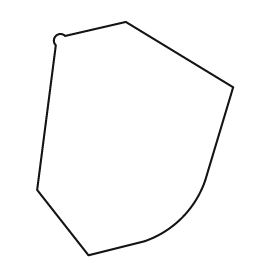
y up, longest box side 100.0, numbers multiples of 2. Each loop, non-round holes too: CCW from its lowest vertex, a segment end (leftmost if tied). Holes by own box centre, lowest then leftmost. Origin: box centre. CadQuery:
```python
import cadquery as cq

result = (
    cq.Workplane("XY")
    .moveTo(-20.0, -50.0)
    .lineTo(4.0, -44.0)
    .threePointArc((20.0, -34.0), (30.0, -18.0))
    .lineTo(42.0, 22.0)
    .lineTo(-4.0, 50.0)
    .lineTo(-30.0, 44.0)
    .threePointArc((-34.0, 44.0), (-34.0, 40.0))
    .lineTo(-42.0, -22.0)
    .close()
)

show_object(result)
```